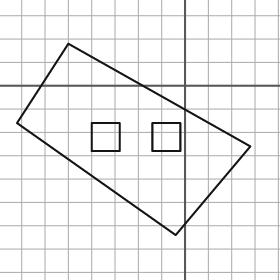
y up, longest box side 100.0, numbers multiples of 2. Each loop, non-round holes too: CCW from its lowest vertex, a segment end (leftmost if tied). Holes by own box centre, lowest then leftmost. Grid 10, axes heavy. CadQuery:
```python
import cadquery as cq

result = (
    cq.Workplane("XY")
    .moveTo(-4.0, -64.0)
    .lineTo(28.0, -26.0)
    .lineTo(-50.0, 18.0)
    .lineTo(-72.0, -16.0)
    .close()
    .moveTo(-40.0, -28.0)
    .lineTo(-28.0, -28.0)
    .lineTo(-28.0, -16.0)
    .lineTo(-40.0, -16.0)
    .close()
    .moveTo(-14.0, -28.0)
    .lineTo(-2.0, -28.0)
    .lineTo(-2.0, -16.0)
    .lineTo(-14.0, -16.0)
    .close()
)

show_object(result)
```